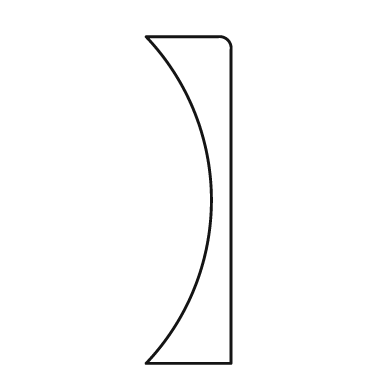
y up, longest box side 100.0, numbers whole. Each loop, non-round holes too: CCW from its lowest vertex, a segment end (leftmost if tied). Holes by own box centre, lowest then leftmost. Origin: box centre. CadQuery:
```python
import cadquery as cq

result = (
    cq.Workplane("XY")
    .moveTo(-13.0, -50.0)
    .lineTo(13.0, -50.0)
    .lineTo(13.0, 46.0)
    .threePointArc((12.0, 49.0), (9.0, 50.0))
    .lineTo(-13.0, 50.0)
    .threePointArc((7.0, 0.0), (-13.0, -50.0))
    .close()
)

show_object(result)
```